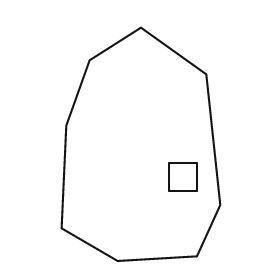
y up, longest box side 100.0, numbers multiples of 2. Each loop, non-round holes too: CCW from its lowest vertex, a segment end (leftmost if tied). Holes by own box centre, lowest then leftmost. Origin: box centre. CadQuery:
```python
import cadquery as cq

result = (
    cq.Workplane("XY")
    .moveTo(-10.0, -50.0)
    .lineTo(24.0, -48.0)
    .lineTo(34.0, -26.0)
    .lineTo(28.0, 30.0)
    .lineTo(0.0, 50.0)
    .lineTo(-22.0, 36.0)
    .lineTo(-32.0, 8.0)
    .lineTo(-34.0, -36.0)
    .close()
    .moveTo(12.0, -20.0)
    .lineTo(24.0, -20.0)
    .lineTo(24.0, -8.0)
    .lineTo(12.0, -8.0)
    .close()
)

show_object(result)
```